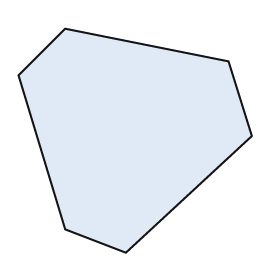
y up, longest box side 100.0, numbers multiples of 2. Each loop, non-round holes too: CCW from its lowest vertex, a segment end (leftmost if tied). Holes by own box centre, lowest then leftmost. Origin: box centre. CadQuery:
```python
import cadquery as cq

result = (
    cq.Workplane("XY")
    .moveTo(-4.0, -48.0)
    .lineTo(50.0, 2.0)
    .lineTo(40.0, 34.0)
    .lineTo(-30.0, 48.0)
    .lineTo(-50.0, 28.0)
    .lineTo(-30.0, -38.0)
    .close()
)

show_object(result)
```